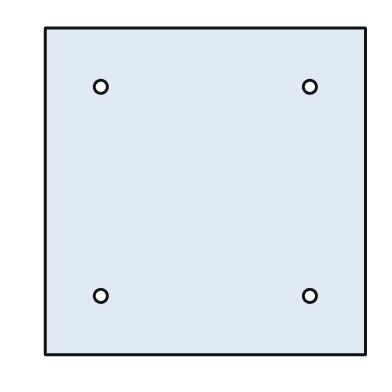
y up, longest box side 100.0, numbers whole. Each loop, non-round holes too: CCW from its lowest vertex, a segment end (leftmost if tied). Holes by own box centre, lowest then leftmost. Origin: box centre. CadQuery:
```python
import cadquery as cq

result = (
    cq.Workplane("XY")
    .moveTo(-49.0, -50.0)
    .lineTo(49.0, -50.0)
    .lineTo(49.0, 50.0)
    .lineTo(-49.0, 50.0)
    .close()
    .moveTo(-32.0, -32.0)
    .circle(2.0)
    .moveTo(32.0, -32.0)
    .circle(2.0)
    .moveTo(-32.0, 32.0)
    .circle(2.0)
    .moveTo(32.0, 32.0)
    .circle(2.0)
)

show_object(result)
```